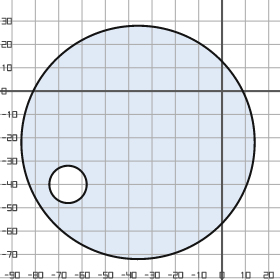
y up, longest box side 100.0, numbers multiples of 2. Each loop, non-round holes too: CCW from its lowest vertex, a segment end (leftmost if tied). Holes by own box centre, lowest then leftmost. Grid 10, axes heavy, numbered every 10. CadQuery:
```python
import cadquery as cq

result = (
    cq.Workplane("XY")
    .moveTo(-36.0, -22.0)
    .circle(50.0)
    .moveTo(-66.0, -40.0)
    .circle(8.0)
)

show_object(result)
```